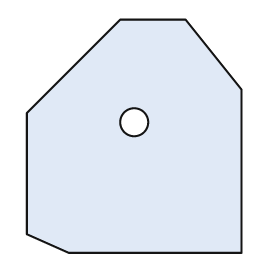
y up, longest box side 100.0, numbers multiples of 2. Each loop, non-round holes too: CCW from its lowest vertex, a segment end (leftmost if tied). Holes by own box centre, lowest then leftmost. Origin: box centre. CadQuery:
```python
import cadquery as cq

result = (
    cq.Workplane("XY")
    .moveTo(-28.0, -50.0)
    .lineTo(46.0, -50.0)
    .lineTo(46.0, 20.0)
    .lineTo(22.0, 50.0)
    .lineTo(-6.0, 50.0)
    .lineTo(-46.0, 10.0)
    .lineTo(-46.0, -42.0)
    .close()
    .moveTo(0.0, 6.0)
    .circle(6.0)
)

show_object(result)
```